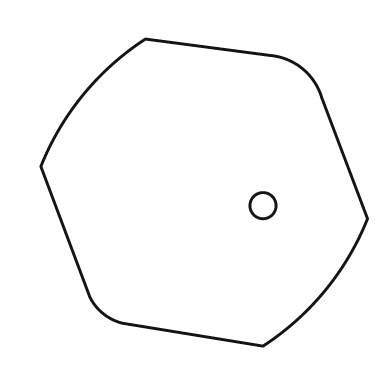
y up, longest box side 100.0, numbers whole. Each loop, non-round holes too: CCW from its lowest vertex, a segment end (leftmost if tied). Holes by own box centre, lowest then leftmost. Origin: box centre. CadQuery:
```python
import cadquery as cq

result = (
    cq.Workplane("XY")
    .moveTo(18.0, -47.0)
    .threePointArc((37.0, -30.0), (50.0, -8.0))
    .lineTo(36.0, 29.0)
    .threePointArc((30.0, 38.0), (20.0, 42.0))
    .lineTo(-18.0, 47.0)
    .threePointArc((-37.0, 30.0), (-50.0, 8.0))
    .lineTo(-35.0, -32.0)
    .threePointArc((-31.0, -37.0), (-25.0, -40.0))
    .close()
    .moveTo(18.0, -4.0)
    .circle(4.0)
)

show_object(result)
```